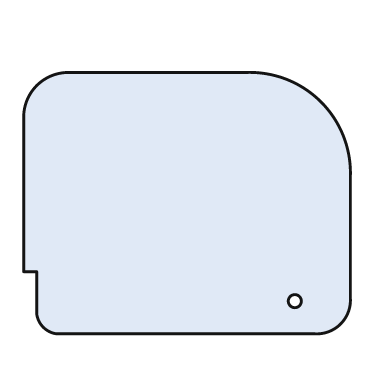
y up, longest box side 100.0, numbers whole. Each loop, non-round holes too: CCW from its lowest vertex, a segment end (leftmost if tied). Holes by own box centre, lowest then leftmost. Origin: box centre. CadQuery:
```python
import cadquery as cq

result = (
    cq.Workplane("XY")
    .moveTo(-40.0, -40.0)
    .lineTo(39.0, -40.0)
    .threePointArc((47.0, -37.0), (50.0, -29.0))
    .lineTo(50.0, 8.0)
    .threePointArc((41.0, 31.0), (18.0, 40.0))
    .lineTo(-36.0, 40.0)
    .threePointArc((-46.0, 36.0), (-50.0, 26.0))
    .lineTo(-50.0, -21.0)
    .lineTo(-46.0, -21.0)
    .lineTo(-46.0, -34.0)
    .threePointArc((-44.0, -38.0), (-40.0, -40.0))
    .close()
    .moveTo(33.0, -30.0)
    .circle(2.0)
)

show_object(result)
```